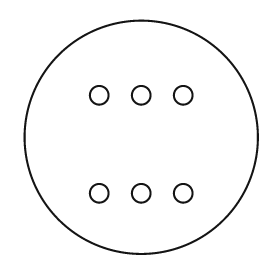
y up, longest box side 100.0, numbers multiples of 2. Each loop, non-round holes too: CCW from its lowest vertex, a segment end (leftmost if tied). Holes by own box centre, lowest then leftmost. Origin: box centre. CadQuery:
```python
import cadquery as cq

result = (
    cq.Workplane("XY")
    .moveTo(0.0, 0.0)
    .circle(50.0)
    .moveTo(-18.0, -24.0)
    .circle(4.0)
    .moveTo(0.0, -24.0)
    .circle(4.0)
    .moveTo(18.0, -24.0)
    .circle(4.0)
    .moveTo(-18.0, 18.0)
    .circle(4.0)
    .moveTo(0.0, 18.0)
    .circle(4.0)
    .moveTo(18.0, 18.0)
    .circle(4.0)
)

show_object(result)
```